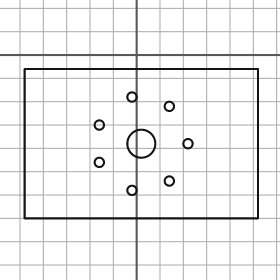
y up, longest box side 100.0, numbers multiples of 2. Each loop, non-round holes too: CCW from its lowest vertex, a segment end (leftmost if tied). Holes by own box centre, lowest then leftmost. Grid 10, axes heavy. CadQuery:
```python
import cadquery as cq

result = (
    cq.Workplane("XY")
    .moveTo(-48.0, -70.0)
    .lineTo(52.0, -70.0)
    .lineTo(52.0, -6.0)
    .lineTo(-48.0, -6.0)
    .close()
    .moveTo(-2.0, -58.0)
    .circle(2.0)
    .moveTo(14.0, -54.0)
    .circle(2.0)
    .moveTo(-16.0, -46.0)
    .circle(2.0)
    .moveTo(2.0, -38.0)
    .circle(6.0)
    .moveTo(22.0, -38.0)
    .circle(2.0)
    .moveTo(-16.0, -30.0)
    .circle(2.0)
    .moveTo(14.0, -22.0)
    .circle(2.0)
    .moveTo(-2.0, -18.0)
    .circle(2.0)
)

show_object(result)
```